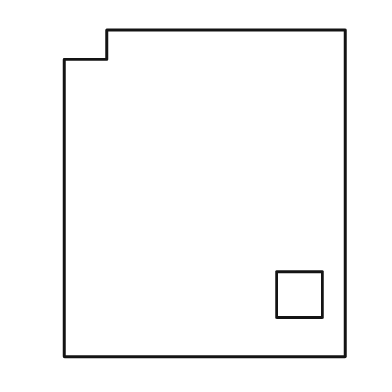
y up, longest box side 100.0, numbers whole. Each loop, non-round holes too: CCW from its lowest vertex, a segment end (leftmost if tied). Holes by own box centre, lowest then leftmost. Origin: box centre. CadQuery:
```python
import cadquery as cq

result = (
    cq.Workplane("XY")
    .moveTo(-43.0, -50.0)
    .lineTo(43.0, -50.0)
    .lineTo(43.0, 50.0)
    .lineTo(-30.0, 50.0)
    .lineTo(-30.0, 41.0)
    .lineTo(-43.0, 41.0)
    .close()
    .moveTo(22.0, -38.0)
    .lineTo(36.0, -38.0)
    .lineTo(36.0, -24.0)
    .lineTo(22.0, -24.0)
    .close()
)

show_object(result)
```